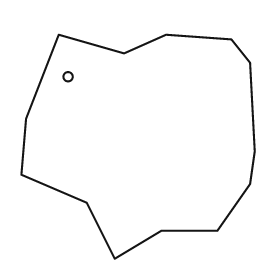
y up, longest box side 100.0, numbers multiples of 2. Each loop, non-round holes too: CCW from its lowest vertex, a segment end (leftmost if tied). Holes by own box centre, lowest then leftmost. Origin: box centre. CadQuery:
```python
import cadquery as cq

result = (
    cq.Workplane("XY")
    .moveTo(-10.0, -48.0)
    .lineTo(10.0, -36.0)
    .lineTo(34.0, -36.0)
    .lineTo(48.0, -16.0)
    .lineTo(50.0, -2.0)
    .lineTo(48.0, 36.0)
    .lineTo(40.0, 46.0)
    .lineTo(12.0, 48.0)
    .lineTo(-6.0, 40.0)
    .lineTo(-34.0, 48.0)
    .lineTo(-48.0, 12.0)
    .lineTo(-50.0, -12.0)
    .lineTo(-22.0, -24.0)
    .close()
    .moveTo(-30.0, 30.0)
    .circle(2.0)
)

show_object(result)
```